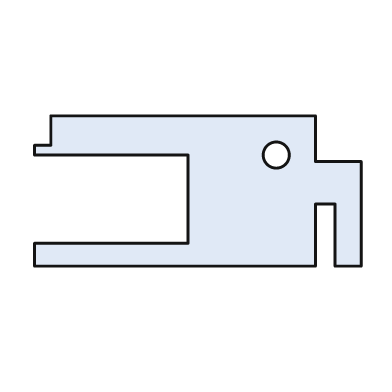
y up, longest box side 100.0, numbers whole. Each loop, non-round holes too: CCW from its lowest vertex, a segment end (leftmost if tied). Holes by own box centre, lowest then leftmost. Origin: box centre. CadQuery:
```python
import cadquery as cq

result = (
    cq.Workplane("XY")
    .moveTo(-50.0, -23.0)
    .lineTo(36.0, -23.0)
    .lineTo(36.0, -4.0)
    .lineTo(42.0, -4.0)
    .lineTo(42.0, -23.0)
    .lineTo(50.0, -23.0)
    .lineTo(50.0, 9.0)
    .lineTo(36.0, 9.0)
    .lineTo(36.0, 23.0)
    .lineTo(-45.0, 23.0)
    .lineTo(-45.0, 14.0)
    .lineTo(-50.0, 14.0)
    .lineTo(-50.0, 11.0)
    .lineTo(-3.0, 11.0)
    .lineTo(-3.0, -16.0)
    .lineTo(-50.0, -16.0)
    .close()
    .moveTo(24.0, 11.0)
    .circle(4.0)
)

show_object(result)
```